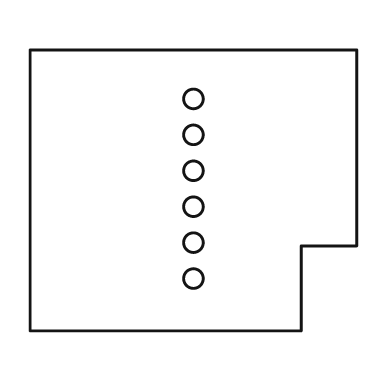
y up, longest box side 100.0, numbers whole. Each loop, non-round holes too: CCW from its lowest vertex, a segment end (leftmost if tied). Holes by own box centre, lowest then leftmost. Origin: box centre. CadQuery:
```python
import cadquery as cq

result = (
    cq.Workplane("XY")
    .moveTo(-50.0, -43.0)
    .lineTo(33.0, -43.0)
    .lineTo(33.0, -17.0)
    .lineTo(50.0, -17.0)
    .lineTo(50.0, 43.0)
    .lineTo(-50.0, 43.0)
    .close()
    .moveTo(0.0, -27.0)
    .circle(3.0)
    .moveTo(0.0, -16.0)
    .circle(3.0)
    .moveTo(0.0, -5.0)
    .circle(3.0)
    .moveTo(0.0, 6.0)
    .circle(3.0)
    .moveTo(0.0, 17.0)
    .circle(3.0)
    .moveTo(0.0, 28.0)
    .circle(3.0)
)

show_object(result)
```